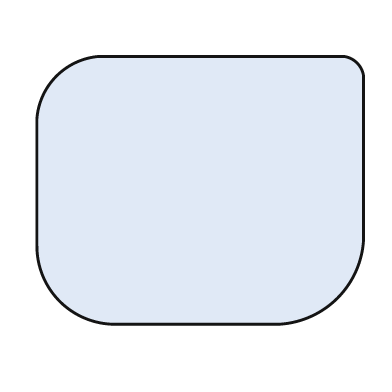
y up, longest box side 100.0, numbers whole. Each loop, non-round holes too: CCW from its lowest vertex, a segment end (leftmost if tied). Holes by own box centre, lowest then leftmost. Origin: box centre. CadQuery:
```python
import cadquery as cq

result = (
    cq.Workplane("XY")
    .moveTo(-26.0, -41.0)
    .lineTo(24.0, -41.0)
    .threePointArc((42.0, -33.0), (50.0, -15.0))
    .lineTo(50.0, 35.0)
    .threePointArc((48.0, 39.0), (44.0, 41.0))
    .lineTo(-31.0, 41.0)
    .threePointArc((-44.0, 35.0), (-50.0, 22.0))
    .lineTo(-50.0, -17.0)
    .threePointArc((-43.0, -34.0), (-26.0, -41.0))
    .close()
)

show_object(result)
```